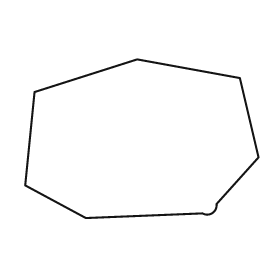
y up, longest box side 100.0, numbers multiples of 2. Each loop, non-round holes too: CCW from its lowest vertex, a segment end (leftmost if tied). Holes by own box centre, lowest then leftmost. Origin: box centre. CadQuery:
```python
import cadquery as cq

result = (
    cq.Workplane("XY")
    .moveTo(-24.0, -34.0)
    .lineTo(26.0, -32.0)
    .threePointArc((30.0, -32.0), (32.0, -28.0))
    .lineTo(50.0, -8.0)
    .lineTo(42.0, 26.0)
    .lineTo(-2.0, 34.0)
    .lineTo(-46.0, 20.0)
    .lineTo(-50.0, -20.0)
    .close()
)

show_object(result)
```